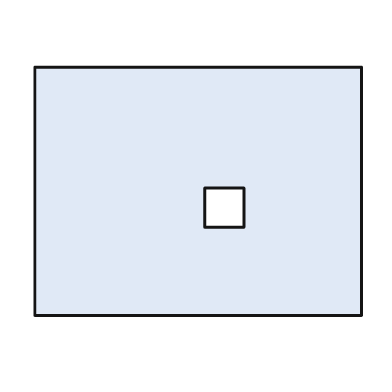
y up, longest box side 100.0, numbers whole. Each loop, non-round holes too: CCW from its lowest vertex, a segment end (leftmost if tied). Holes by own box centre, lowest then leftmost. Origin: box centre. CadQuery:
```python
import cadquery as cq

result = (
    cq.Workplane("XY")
    .moveTo(-50.0, -38.0)
    .lineTo(50.0, -38.0)
    .lineTo(50.0, 38.0)
    .lineTo(-50.0, 38.0)
    .close()
    .moveTo(2.0, -11.0)
    .lineTo(14.0, -11.0)
    .lineTo(14.0, 1.0)
    .lineTo(2.0, 1.0)
    .close()
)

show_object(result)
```